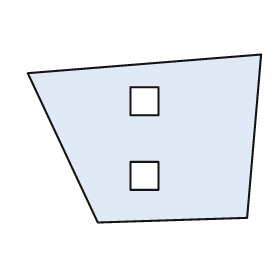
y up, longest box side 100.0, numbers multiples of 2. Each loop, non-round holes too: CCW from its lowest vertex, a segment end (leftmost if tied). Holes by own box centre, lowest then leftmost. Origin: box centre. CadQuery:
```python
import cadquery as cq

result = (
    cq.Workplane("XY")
    .moveTo(-20.0, -36.0)
    .lineTo(44.0, -34.0)
    .lineTo(50.0, 36.0)
    .lineTo(-50.0, 28.0)
    .close()
    .moveTo(-6.0, -22.0)
    .lineTo(6.0, -22.0)
    .lineTo(6.0, -10.0)
    .lineTo(-6.0, -10.0)
    .close()
    .moveTo(-6.0, 10.0)
    .lineTo(6.0, 10.0)
    .lineTo(6.0, 22.0)
    .lineTo(-6.0, 22.0)
    .close()
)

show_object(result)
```